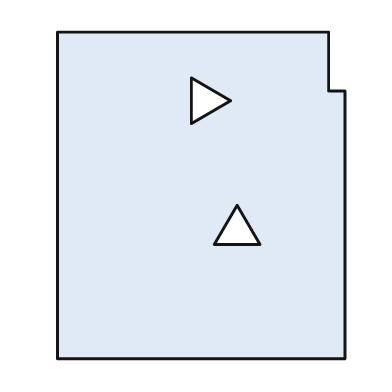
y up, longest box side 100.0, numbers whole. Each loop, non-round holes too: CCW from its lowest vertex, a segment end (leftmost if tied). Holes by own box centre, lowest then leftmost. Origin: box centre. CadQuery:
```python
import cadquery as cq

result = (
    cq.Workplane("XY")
    .moveTo(-44.0, -50.0)
    .lineTo(44.0, -50.0)
    .lineTo(44.0, 32.0)
    .lineTo(39.0, 32.0)
    .lineTo(39.0, 50.0)
    .lineTo(-44.0, 50.0)
    .close()
    .moveTo(4.0, -15.0)
    .lineTo(18.0, -15.0)
    .lineTo(11.0, -3.0)
    .close()
    .moveTo(-3.0, 22.0)
    .lineTo(9.0, 29.0)
    .lineTo(-3.0, 36.0)
    .close()
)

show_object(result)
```